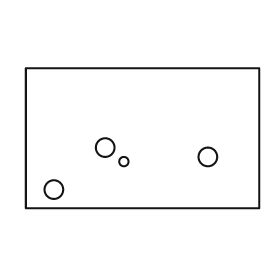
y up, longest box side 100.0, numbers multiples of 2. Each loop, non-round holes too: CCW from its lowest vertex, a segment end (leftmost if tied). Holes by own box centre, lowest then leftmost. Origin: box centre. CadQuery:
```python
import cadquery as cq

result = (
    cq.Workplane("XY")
    .moveTo(-50.0, -30.0)
    .lineTo(50.0, -30.0)
    .lineTo(50.0, 30.0)
    .lineTo(-50.0, 30.0)
    .close()
    .moveTo(-38.0, -22.0)
    .circle(4.0)
    .moveTo(-8.0, -10.0)
    .circle(2.0)
    .moveTo(28.0, -8.0)
    .circle(4.0)
    .moveTo(-16.0, -4.0)
    .circle(4.0)
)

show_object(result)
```